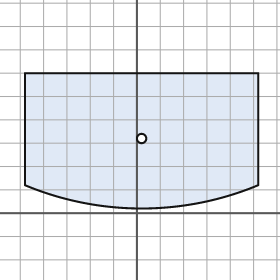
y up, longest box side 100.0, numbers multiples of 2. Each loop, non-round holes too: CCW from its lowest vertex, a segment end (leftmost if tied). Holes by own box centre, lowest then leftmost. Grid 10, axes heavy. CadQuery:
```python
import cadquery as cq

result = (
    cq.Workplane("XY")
    .moveTo(-48.0, 12.0)
    .threePointArc((2.0, 2.0), (52.0, 12.0))
    .lineTo(52.0, 60.0)
    .lineTo(-48.0, 60.0)
    .close()
    .moveTo(2.0, 32.0)
    .circle(2.0)
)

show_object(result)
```